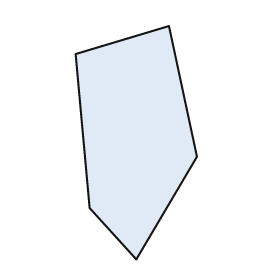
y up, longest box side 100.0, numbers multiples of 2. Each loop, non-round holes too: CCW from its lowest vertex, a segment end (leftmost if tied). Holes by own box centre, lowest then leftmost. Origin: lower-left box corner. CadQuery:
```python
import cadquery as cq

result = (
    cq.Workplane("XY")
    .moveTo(26.0, 0.0)
    .lineTo(52.0, 44.0)
    .lineTo(40.0, 100.0)
    .lineTo(0.0, 88.0)
    .lineTo(6.0, 22.0)
    .close()
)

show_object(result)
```